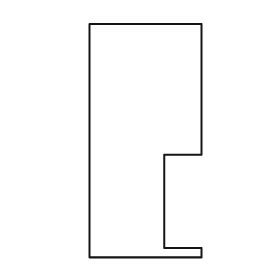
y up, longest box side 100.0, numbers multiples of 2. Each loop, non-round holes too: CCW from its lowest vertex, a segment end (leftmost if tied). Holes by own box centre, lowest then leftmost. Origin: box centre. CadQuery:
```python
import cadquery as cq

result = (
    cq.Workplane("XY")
    .moveTo(-24.0, -50.0)
    .lineTo(24.0, -50.0)
    .lineTo(24.0, -46.0)
    .lineTo(8.0, -46.0)
    .lineTo(8.0, -6.0)
    .lineTo(24.0, -6.0)
    .lineTo(24.0, 50.0)
    .lineTo(-24.0, 50.0)
    .close()
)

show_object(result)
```